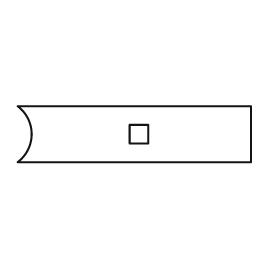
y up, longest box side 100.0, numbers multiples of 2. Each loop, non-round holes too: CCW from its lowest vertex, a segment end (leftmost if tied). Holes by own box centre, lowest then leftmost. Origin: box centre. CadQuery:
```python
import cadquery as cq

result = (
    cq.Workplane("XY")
    .moveTo(-50.0, -12.0)
    .lineTo(50.0, -12.0)
    .lineTo(50.0, 12.0)
    .lineTo(-50.0, 12.0)
    .threePointArc((-44.0, 0.0), (-50.0, -12.0))
    .close()
    .moveTo(-2.0, -4.0)
    .lineTo(6.0, -4.0)
    .lineTo(6.0, 4.0)
    .lineTo(-2.0, 4.0)
    .close()
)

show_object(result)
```